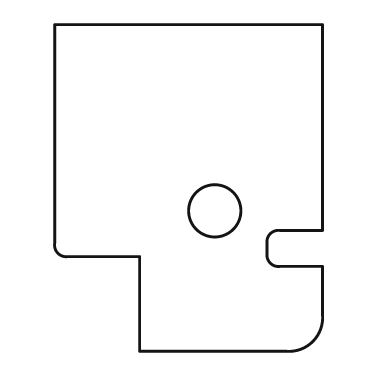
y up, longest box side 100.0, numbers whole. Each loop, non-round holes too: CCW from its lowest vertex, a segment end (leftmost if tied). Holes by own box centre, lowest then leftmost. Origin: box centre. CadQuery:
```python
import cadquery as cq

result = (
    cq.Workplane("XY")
    .moveTo(-15.0, -50.0)
    .lineTo(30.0, -50.0)
    .threePointArc((38.0, -47.0), (41.0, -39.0))
    .lineTo(41.0, -24.0)
    .lineTo(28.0, -24.0)
    .threePointArc((25.0, -23.0), (24.0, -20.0))
    .lineTo(24.0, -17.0)
    .threePointArc((25.0, -14.0), (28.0, -13.0))
    .lineTo(41.0, -13.0)
    .lineTo(41.0, 50.0)
    .lineTo(-41.0, 50.0)
    .lineTo(-41.0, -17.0)
    .threePointArc((-40.0, -20.0), (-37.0, -21.0))
    .lineTo(-15.0, -21.0)
    .close()
    .moveTo(8.0, -7.0)
    .circle(8.0)
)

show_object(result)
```